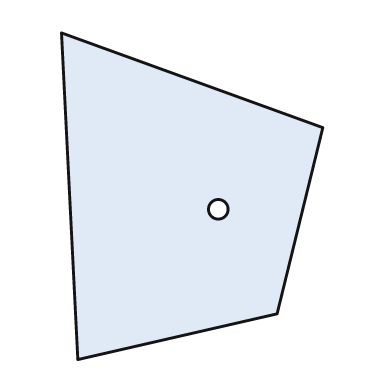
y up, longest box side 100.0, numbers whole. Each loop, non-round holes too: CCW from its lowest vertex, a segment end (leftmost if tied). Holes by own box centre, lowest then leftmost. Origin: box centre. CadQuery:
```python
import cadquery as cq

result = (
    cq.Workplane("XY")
    .moveTo(-35.0, -50.0)
    .lineTo(26.0, -36.0)
    .lineTo(40.0, 21.0)
    .lineTo(-40.0, 50.0)
    .close()
    .moveTo(8.0, -4.0)
    .circle(3.0)
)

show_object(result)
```